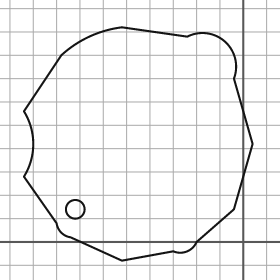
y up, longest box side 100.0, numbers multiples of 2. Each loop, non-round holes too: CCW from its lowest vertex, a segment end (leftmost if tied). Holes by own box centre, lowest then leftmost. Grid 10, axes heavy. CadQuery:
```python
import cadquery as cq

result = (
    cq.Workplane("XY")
    .moveTo(-52.0, -8.0)
    .lineTo(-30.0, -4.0)
    .threePointArc((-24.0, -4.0), (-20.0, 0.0))
    .lineTo(-4.0, 14.0)
    .lineTo(4.0, 42.0)
    .lineTo(-4.0, 70.0)
    .threePointArc((-8.0, 86.0), (-24.0, 88.0))
    .lineTo(-52.0, 92.0)
    .threePointArc((-66.0, 88.0), (-78.0, 80.0))
    .lineTo(-94.0, 56.0)
    .threePointArc((-90.0, 42.0), (-94.0, 28.0))
    .lineTo(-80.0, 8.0)
    .threePointArc((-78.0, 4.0), (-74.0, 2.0))
    .close()
    .moveTo(-72.0, 14.0)
    .circle(4.0)
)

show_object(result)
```